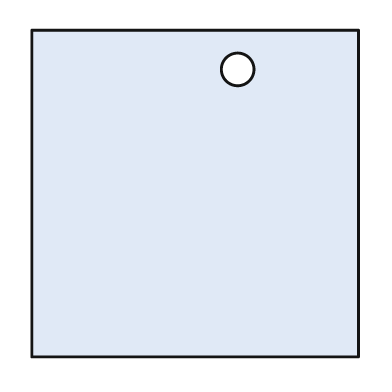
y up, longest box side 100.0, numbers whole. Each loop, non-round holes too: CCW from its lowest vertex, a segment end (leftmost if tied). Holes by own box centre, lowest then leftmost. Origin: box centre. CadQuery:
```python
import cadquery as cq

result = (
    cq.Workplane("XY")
    .moveTo(-50.0, -50.0)
    .lineTo(50.0, -50.0)
    .lineTo(50.0, 50.0)
    .lineTo(-50.0, 50.0)
    .close()
    .moveTo(13.0, 38.0)
    .circle(5.0)
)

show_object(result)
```